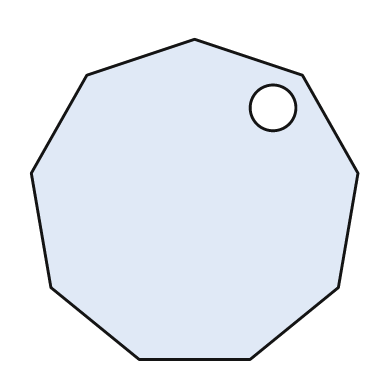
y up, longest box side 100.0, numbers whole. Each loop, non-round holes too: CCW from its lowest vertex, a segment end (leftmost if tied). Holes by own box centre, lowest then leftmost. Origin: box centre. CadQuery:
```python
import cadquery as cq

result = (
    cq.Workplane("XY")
    .moveTo(-17.0, -49.0)
    .lineTo(17.0, -49.0)
    .lineTo(44.0, -27.0)
    .lineTo(50.0, 8.0)
    .lineTo(33.0, 38.0)
    .lineTo(0.0, 49.0)
    .lineTo(-33.0, 38.0)
    .lineTo(-50.0, 8.0)
    .lineTo(-44.0, -27.0)
    .close()
    .moveTo(24.0, 28.0)
    .circle(7.0)
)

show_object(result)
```